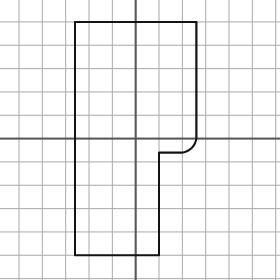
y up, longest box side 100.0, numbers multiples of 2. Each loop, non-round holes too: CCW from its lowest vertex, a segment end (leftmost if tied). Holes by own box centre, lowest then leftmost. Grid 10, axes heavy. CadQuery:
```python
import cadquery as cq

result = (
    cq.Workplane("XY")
    .moveTo(-26.0, -50.0)
    .lineTo(10.0, -50.0)
    .lineTo(10.0, -6.0)
    .lineTo(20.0, -6.0)
    .threePointArc((24.0, -4.0), (26.0, 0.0))
    .lineTo(26.0, 50.0)
    .lineTo(-26.0, 50.0)
    .close()
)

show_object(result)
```